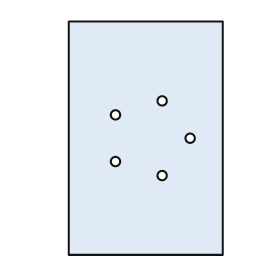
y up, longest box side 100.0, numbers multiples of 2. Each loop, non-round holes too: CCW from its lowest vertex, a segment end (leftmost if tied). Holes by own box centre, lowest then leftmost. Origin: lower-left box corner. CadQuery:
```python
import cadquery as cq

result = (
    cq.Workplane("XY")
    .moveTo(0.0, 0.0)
    .lineTo(66.0, 0.0)
    .lineTo(66.0, 100.0)
    .lineTo(0.0, 100.0)
    .close()
    .moveTo(40.0, 34.0)
    .circle(2.0)
    .moveTo(20.0, 40.0)
    .circle(2.0)
    .moveTo(52.0, 50.0)
    .circle(2.0)
    .moveTo(20.0, 60.0)
    .circle(2.0)
    .moveTo(40.0, 66.0)
    .circle(2.0)
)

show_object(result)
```